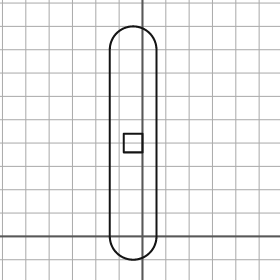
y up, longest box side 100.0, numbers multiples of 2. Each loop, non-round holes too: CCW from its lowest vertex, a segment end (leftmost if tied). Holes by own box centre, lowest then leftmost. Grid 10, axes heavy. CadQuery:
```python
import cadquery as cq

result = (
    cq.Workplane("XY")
    .moveTo(-14.0, 0.0)
    .threePointArc((-4.0, -10.0), (6.0, 0.0))
    .lineTo(6.0, 80.0)
    .threePointArc((-4.0, 90.0), (-14.0, 80.0))
    .close()
    .moveTo(-8.0, 36.0)
    .lineTo(0.0, 36.0)
    .lineTo(0.0, 44.0)
    .lineTo(-8.0, 44.0)
    .close()
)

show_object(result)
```